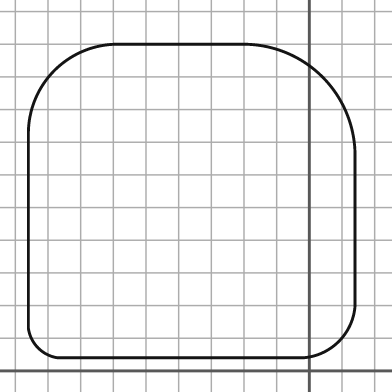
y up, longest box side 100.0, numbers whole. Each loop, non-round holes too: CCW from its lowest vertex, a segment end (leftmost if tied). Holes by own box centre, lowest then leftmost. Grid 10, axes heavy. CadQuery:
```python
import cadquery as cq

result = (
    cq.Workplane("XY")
    .moveTo(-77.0, 4.0)
    .lineTo(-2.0, 4.0)
    .threePointArc((9.0, 9.0), (14.0, 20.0))
    .lineTo(14.0, 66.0)
    .threePointArc((4.0, 90.0), (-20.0, 100.0))
    .lineTo(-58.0, 100.0)
    .threePointArc((-78.0, 92.0), (-86.0, 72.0))
    .lineTo(-86.0, 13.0)
    .threePointArc((-83.0, 7.0), (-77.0, 4.0))
    .close()
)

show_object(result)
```